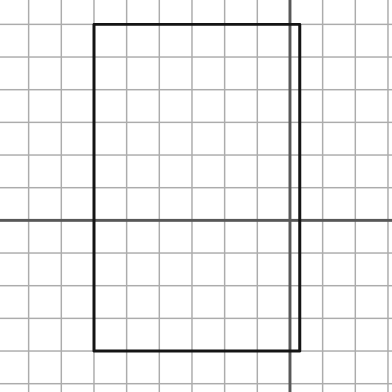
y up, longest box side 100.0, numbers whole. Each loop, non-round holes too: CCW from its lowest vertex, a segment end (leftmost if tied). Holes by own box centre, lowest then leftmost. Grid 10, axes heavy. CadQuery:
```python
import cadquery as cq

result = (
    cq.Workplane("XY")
    .moveTo(-60.0, -40.0)
    .lineTo(3.0, -40.0)
    .lineTo(3.0, 60.0)
    .lineTo(-60.0, 60.0)
    .close()
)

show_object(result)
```